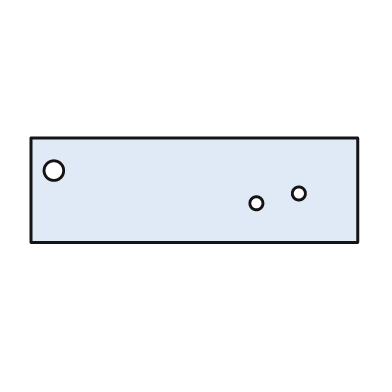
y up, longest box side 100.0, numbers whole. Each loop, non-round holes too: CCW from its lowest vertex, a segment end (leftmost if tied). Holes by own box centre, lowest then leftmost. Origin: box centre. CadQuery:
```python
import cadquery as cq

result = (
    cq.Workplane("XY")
    .moveTo(-50.0, -16.0)
    .lineTo(50.0, -16.0)
    .lineTo(50.0, 16.0)
    .lineTo(-50.0, 16.0)
    .close()
    .moveTo(19.0, -4.0)
    .circle(2.0)
    .moveTo(32.0, -1.0)
    .circle(2.0)
    .moveTo(-43.0, 6.0)
    .circle(3.0)
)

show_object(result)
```